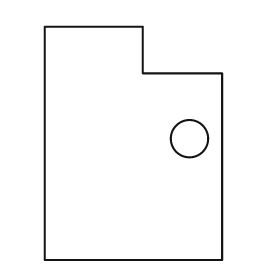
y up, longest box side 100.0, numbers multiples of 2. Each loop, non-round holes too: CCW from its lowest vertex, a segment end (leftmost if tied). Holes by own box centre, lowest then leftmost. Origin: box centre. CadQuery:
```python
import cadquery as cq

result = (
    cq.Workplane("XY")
    .moveTo(-38.0, -50.0)
    .lineTo(38.0, -50.0)
    .lineTo(38.0, 30.0)
    .lineTo(4.0, 30.0)
    .lineTo(4.0, 50.0)
    .lineTo(-38.0, 50.0)
    .close()
    .moveTo(24.0, 2.0)
    .circle(8.0)
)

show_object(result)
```